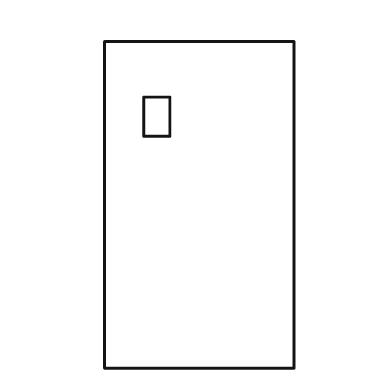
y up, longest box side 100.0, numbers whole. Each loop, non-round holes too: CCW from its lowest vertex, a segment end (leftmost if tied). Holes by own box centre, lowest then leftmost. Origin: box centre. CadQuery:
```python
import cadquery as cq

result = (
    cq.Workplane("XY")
    .moveTo(-29.0, -50.0)
    .lineTo(29.0, -50.0)
    .lineTo(29.0, 50.0)
    .lineTo(-29.0, 50.0)
    .close()
    .moveTo(-17.0, 21.0)
    .lineTo(-9.0, 21.0)
    .lineTo(-9.0, 33.0)
    .lineTo(-17.0, 33.0)
    .close()
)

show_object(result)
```